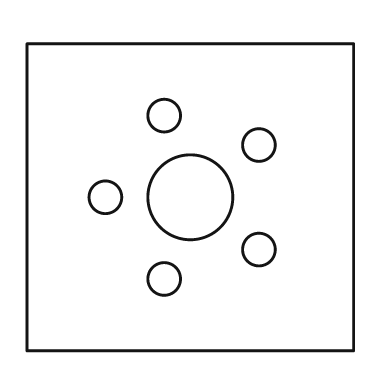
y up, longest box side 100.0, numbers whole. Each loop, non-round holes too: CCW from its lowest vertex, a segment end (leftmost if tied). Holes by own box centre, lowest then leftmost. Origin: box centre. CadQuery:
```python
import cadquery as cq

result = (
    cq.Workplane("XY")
    .moveTo(-50.0, -47.0)
    .lineTo(50.0, -47.0)
    .lineTo(50.0, 47.0)
    .lineTo(-50.0, 47.0)
    .close()
    .moveTo(-8.0, -25.0)
    .circle(5.0)
    .moveTo(21.0, -16.0)
    .circle(5.0)
    .moveTo(-26.0, 0.0)
    .circle(5.0)
    .moveTo(0.0, 0.0)
    .circle(13.0)
    .moveTo(21.0, 16.0)
    .circle(5.0)
    .moveTo(-8.0, 25.0)
    .circle(5.0)
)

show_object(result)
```